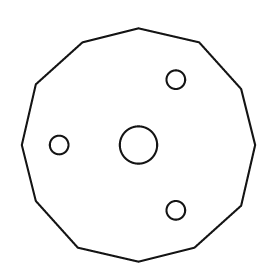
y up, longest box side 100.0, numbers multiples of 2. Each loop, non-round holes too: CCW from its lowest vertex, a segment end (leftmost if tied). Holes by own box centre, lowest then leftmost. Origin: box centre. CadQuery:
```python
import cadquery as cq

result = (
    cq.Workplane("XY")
    .moveTo(0.0, -50.0)
    .lineTo(24.0, -44.0)
    .lineTo(44.0, -26.0)
    .lineTo(50.0, 0.0)
    .lineTo(44.0, 24.0)
    .lineTo(26.0, 44.0)
    .lineTo(0.0, 50.0)
    .lineTo(-24.0, 44.0)
    .lineTo(-44.0, 26.0)
    .lineTo(-50.0, 0.0)
    .lineTo(-44.0, -24.0)
    .lineTo(-26.0, -44.0)
    .close()
    .moveTo(16.0, -28.0)
    .circle(4.0)
    .moveTo(-34.0, 0.0)
    .circle(4.0)
    .moveTo(0.0, 0.0)
    .circle(8.0)
    .moveTo(16.0, 28.0)
    .circle(4.0)
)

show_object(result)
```